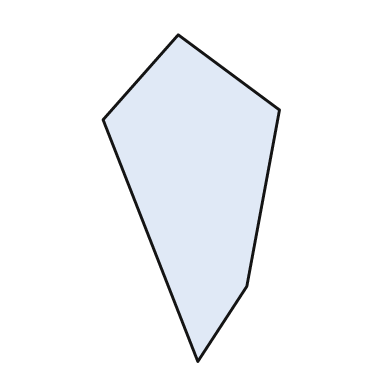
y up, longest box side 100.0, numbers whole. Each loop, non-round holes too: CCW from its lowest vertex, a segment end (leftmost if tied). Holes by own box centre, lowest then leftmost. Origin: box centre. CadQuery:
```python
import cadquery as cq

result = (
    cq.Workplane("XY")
    .moveTo(2.0, -50.0)
    .lineTo(17.0, -27.0)
    .lineTo(27.0, 27.0)
    .lineTo(-4.0, 50.0)
    .lineTo(-27.0, 24.0)
    .close()
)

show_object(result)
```